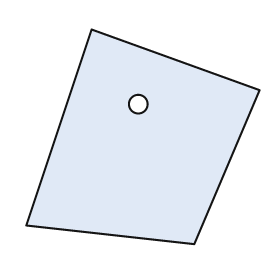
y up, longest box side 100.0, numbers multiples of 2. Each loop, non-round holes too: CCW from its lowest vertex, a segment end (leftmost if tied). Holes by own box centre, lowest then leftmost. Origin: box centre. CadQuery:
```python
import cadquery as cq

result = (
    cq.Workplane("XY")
    .moveTo(22.0, -46.0)
    .lineTo(50.0, 20.0)
    .lineTo(-22.0, 46.0)
    .lineTo(-50.0, -38.0)
    .close()
    .moveTo(-2.0, 14.0)
    .circle(4.0)
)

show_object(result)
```